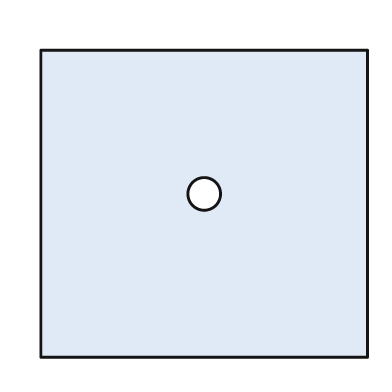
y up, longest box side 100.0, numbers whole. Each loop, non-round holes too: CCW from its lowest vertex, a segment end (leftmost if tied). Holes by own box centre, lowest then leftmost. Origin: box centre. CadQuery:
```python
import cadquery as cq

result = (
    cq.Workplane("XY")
    .moveTo(-50.0, -47.0)
    .lineTo(50.0, -47.0)
    .lineTo(50.0, 47.0)
    .lineTo(-50.0, 47.0)
    .close()
    .moveTo(0.0, 3.0)
    .circle(5.0)
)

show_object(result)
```